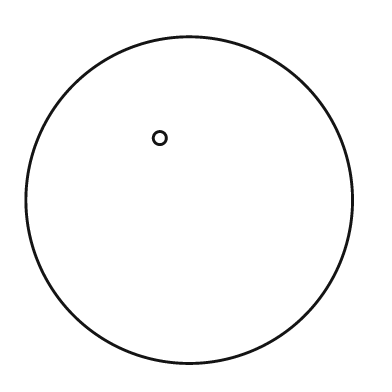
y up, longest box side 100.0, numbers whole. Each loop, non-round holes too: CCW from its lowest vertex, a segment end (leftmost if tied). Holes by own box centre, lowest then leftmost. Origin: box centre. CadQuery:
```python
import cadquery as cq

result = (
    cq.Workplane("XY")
    .moveTo(0.0, 0.0)
    .circle(50.0)
    .moveTo(-9.0, 19.0)
    .circle(2.0)
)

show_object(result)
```